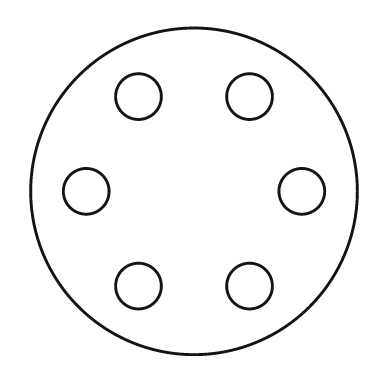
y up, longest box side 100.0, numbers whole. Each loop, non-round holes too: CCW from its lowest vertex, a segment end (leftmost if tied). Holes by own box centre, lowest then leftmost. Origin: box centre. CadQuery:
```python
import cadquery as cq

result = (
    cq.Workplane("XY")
    .moveTo(0.0, 0.0)
    .circle(50.0)
    .moveTo(-17.0, -29.0)
    .circle(7.0)
    .moveTo(17.0, -29.0)
    .circle(7.0)
    .moveTo(-33.0, 0.0)
    .circle(7.0)
    .moveTo(33.0, 0.0)
    .circle(7.0)
    .moveTo(-17.0, 29.0)
    .circle(7.0)
    .moveTo(17.0, 29.0)
    .circle(7.0)
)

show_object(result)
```